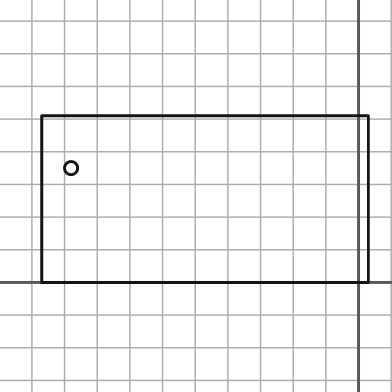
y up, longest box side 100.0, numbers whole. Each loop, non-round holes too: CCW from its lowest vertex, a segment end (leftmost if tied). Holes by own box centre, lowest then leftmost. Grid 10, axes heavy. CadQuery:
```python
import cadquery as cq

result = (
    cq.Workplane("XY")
    .moveTo(-97.0, 0.0)
    .lineTo(3.0, 0.0)
    .lineTo(3.0, 51.0)
    .lineTo(-97.0, 51.0)
    .close()
    .moveTo(-88.0, 35.0)
    .circle(2.0)
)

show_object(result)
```